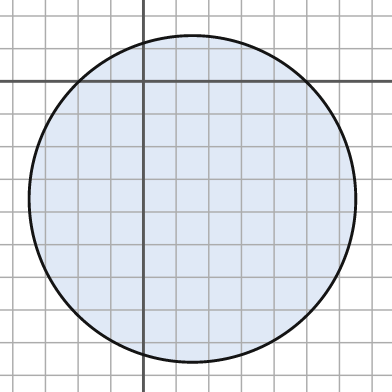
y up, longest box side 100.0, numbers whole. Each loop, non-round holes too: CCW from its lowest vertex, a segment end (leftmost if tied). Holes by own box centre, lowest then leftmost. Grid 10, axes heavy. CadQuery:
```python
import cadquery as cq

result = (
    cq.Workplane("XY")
    .moveTo(15.0, -36.0)
    .circle(50.0)
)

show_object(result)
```